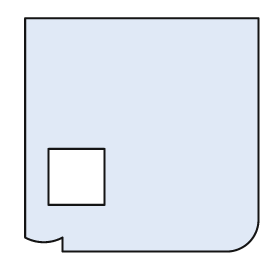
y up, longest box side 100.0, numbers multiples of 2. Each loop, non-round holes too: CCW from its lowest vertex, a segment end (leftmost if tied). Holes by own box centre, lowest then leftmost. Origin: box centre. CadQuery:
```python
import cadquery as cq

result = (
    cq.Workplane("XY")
    .moveTo(-34.0, -50.0)
    .lineTo(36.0, -50.0)
    .threePointArc((46.0, -46.0), (50.0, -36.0))
    .lineTo(50.0, 50.0)
    .lineTo(-50.0, 50.0)
    .lineTo(-50.0, -44.0)
    .threePointArc((-42.0, -46.0), (-34.0, -44.0))
    .close()
    .moveTo(-40.0, -30.0)
    .lineTo(-16.0, -30.0)
    .lineTo(-16.0, -6.0)
    .lineTo(-40.0, -6.0)
    .close()
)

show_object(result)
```